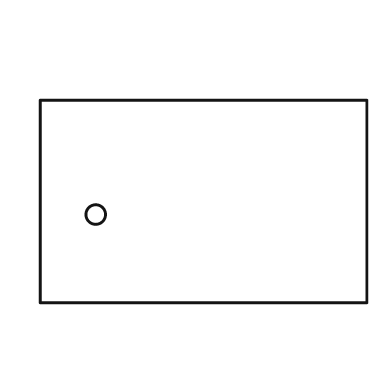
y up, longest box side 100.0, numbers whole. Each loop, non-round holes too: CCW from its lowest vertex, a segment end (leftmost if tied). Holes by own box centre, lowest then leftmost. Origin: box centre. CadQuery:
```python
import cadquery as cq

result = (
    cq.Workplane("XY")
    .moveTo(-50.0, -31.0)
    .lineTo(50.0, -31.0)
    .lineTo(50.0, 31.0)
    .lineTo(-50.0, 31.0)
    .close()
    .moveTo(-33.0, -4.0)
    .circle(3.0)
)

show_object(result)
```